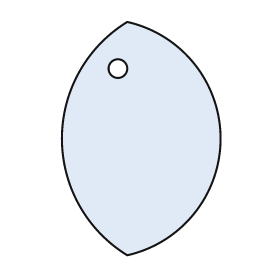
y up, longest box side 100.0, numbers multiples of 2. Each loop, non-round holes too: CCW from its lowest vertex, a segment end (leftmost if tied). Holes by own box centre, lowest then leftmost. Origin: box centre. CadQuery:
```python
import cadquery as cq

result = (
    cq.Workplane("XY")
    .moveTo(-6.0, -50.0)
    .threePointArc((34.0, 0.0), (-6.0, 50.0))
    .threePointArc((-34.0, 0.0), (-6.0, -50.0))
    .close()
    .moveTo(-10.0, 30.0)
    .circle(4.0)
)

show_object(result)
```